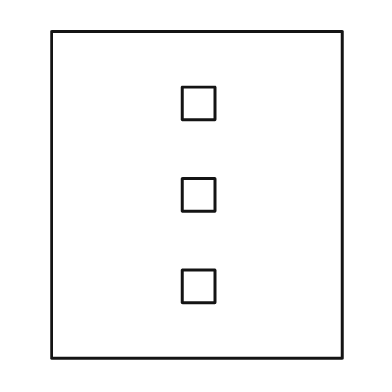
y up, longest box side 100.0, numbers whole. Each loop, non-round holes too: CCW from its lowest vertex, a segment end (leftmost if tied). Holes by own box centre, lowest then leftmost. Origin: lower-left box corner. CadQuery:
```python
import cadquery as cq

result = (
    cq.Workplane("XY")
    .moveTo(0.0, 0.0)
    .lineTo(89.0, 0.0)
    .lineTo(89.0, 100.0)
    .lineTo(0.0, 100.0)
    .close()
    .moveTo(40.0, 17.0)
    .lineTo(50.0, 17.0)
    .lineTo(50.0, 27.0)
    .lineTo(40.0, 27.0)
    .close()
    .moveTo(40.0, 45.0)
    .lineTo(50.0, 45.0)
    .lineTo(50.0, 55.0)
    .lineTo(40.0, 55.0)
    .close()
    .moveTo(40.0, 73.0)
    .lineTo(50.0, 73.0)
    .lineTo(50.0, 83.0)
    .lineTo(40.0, 83.0)
    .close()
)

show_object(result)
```